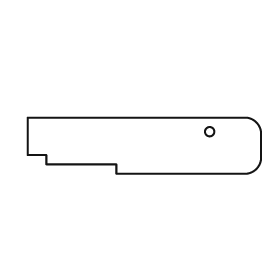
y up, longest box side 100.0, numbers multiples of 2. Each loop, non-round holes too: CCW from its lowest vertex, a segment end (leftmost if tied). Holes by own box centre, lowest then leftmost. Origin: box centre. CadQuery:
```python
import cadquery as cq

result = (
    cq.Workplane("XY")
    .moveTo(-12.0, -12.0)
    .lineTo(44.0, -12.0)
    .threePointArc((48.0, -10.0), (50.0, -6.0))
    .lineTo(50.0, 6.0)
    .threePointArc((48.0, 10.0), (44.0, 12.0))
    .lineTo(-50.0, 12.0)
    .lineTo(-50.0, -4.0)
    .lineTo(-42.0, -4.0)
    .lineTo(-42.0, -8.0)
    .lineTo(-12.0, -8.0)
    .close()
    .moveTo(28.0, 6.0)
    .circle(2.0)
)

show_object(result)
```